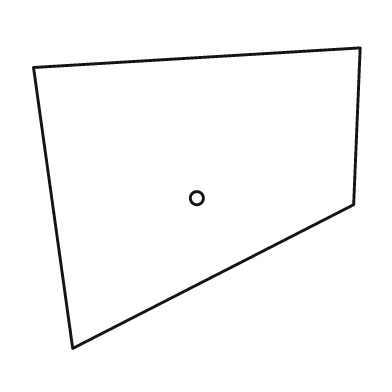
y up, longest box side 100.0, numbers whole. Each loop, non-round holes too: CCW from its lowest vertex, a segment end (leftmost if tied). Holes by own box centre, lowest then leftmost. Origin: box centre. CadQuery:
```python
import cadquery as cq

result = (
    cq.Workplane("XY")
    .moveTo(-38.0, -46.0)
    .lineTo(48.0, -2.0)
    .lineTo(50.0, 46.0)
    .lineTo(-50.0, 40.0)
    .close()
    .moveTo(0.0, 0.0)
    .circle(2.0)
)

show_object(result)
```